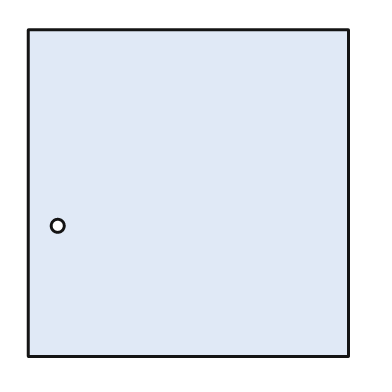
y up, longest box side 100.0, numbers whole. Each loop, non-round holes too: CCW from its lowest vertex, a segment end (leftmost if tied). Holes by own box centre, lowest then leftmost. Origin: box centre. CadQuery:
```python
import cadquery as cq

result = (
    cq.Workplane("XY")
    .moveTo(-49.0, -50.0)
    .lineTo(49.0, -50.0)
    .lineTo(49.0, 50.0)
    .lineTo(-49.0, 50.0)
    .close()
    .moveTo(-40.0, -10.0)
    .circle(2.0)
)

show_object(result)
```